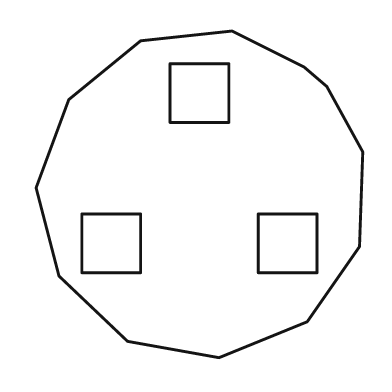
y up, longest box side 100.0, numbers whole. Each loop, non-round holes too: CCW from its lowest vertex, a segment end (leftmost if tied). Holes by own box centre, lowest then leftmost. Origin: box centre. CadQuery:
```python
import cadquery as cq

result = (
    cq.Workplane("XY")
    .moveTo(6.0, -50.0)
    .lineTo(33.0, -39.0)
    .lineTo(49.0, -16.0)
    .lineTo(50.0, 13.0)
    .lineTo(39.0, 33.0)
    .lineTo(32.0, 39.0)
    .lineTo(10.0, 50.0)
    .lineTo(-18.0, 47.0)
    .lineTo(-40.0, 29.0)
    .lineTo(-50.0, 2.0)
    .lineTo(-43.0, -25.0)
    .lineTo(-22.0, -45.0)
    .close()
    .moveTo(-36.0, -24.0)
    .lineTo(-18.0, -24.0)
    .lineTo(-18.0, -6.0)
    .lineTo(-36.0, -6.0)
    .close()
    .moveTo(18.0, -24.0)
    .lineTo(36.0, -24.0)
    .lineTo(36.0, -6.0)
    .lineTo(18.0, -6.0)
    .close()
    .moveTo(-9.0, 22.0)
    .lineTo(9.0, 22.0)
    .lineTo(9.0, 40.0)
    .lineTo(-9.0, 40.0)
    .close()
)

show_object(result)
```